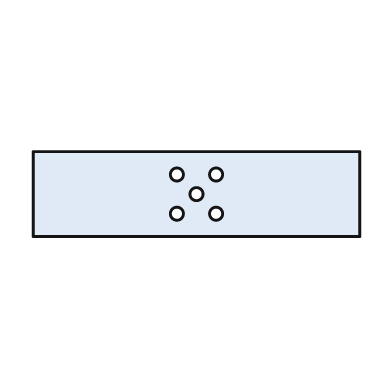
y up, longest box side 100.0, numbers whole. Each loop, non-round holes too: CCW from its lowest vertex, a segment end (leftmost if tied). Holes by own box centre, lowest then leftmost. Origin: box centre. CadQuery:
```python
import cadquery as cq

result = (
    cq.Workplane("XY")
    .moveTo(-50.0, -13.0)
    .lineTo(50.0, -13.0)
    .lineTo(50.0, 13.0)
    .lineTo(-50.0, 13.0)
    .close()
    .moveTo(-6.0, -6.0)
    .circle(2.0)
    .moveTo(6.0, -6.0)
    .circle(2.0)
    .moveTo(0.0, 0.0)
    .circle(2.0)
    .moveTo(-6.0, 6.0)
    .circle(2.0)
    .moveTo(6.0, 6.0)
    .circle(2.0)
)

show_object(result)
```